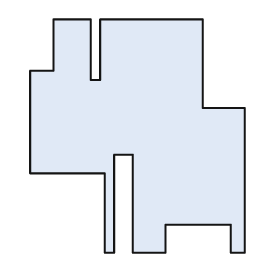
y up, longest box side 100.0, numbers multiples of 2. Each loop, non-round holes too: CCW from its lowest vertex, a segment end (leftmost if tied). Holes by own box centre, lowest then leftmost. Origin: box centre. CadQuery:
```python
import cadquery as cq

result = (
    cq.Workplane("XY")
    .moveTo(-14.0, -50.0)
    .lineTo(-10.0, -50.0)
    .lineTo(-10.0, -8.0)
    .lineTo(-2.0, -8.0)
    .lineTo(-2.0, -50.0)
    .lineTo(12.0, -50.0)
    .lineTo(12.0, -38.0)
    .lineTo(40.0, -38.0)
    .lineTo(40.0, -50.0)
    .lineTo(46.0, -50.0)
    .lineTo(46.0, 12.0)
    .lineTo(28.0, 12.0)
    .lineTo(28.0, 50.0)
    .lineTo(-16.0, 50.0)
    .lineTo(-16.0, 24.0)
    .lineTo(-20.0, 24.0)
    .lineTo(-20.0, 50.0)
    .lineTo(-36.0, 50.0)
    .lineTo(-36.0, 28.0)
    .lineTo(-46.0, 28.0)
    .lineTo(-46.0, -16.0)
    .lineTo(-14.0, -16.0)
    .close()
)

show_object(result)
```